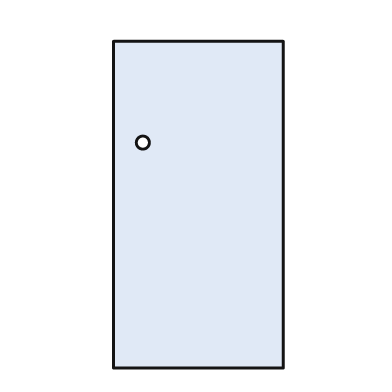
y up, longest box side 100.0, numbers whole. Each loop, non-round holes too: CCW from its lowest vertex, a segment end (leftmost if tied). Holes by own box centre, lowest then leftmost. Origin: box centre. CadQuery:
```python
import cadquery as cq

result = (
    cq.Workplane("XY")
    .moveTo(-26.0, -50.0)
    .lineTo(26.0, -50.0)
    .lineTo(26.0, 50.0)
    .lineTo(-26.0, 50.0)
    .close()
    .moveTo(-17.0, 19.0)
    .circle(2.0)
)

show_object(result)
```